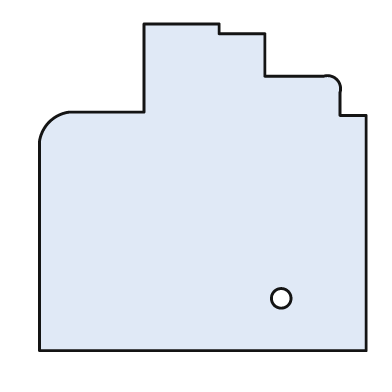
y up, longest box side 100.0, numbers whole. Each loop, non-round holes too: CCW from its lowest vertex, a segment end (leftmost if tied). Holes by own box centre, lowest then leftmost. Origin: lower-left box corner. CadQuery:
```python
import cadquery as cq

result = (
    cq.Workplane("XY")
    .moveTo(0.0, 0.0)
    .lineTo(100.0, 0.0)
    .lineTo(100.0, 72.0)
    .lineTo(92.0, 72.0)
    .lineTo(92.0, 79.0)
    .threePointArc((91.0, 83.0), (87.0, 84.0))
    .lineTo(69.0, 84.0)
    .lineTo(69.0, 97.0)
    .lineTo(55.0, 97.0)
    .lineTo(55.0, 100.0)
    .lineTo(32.0, 100.0)
    .lineTo(32.0, 73.0)
    .lineTo(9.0, 73.0)
    .threePointArc((3.0, 70.0), (0.0, 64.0))
    .close()
    .moveTo(74.0, 16.0)
    .circle(3.0)
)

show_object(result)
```